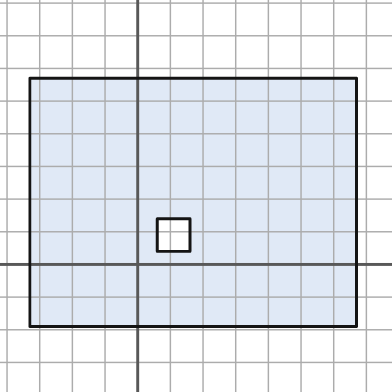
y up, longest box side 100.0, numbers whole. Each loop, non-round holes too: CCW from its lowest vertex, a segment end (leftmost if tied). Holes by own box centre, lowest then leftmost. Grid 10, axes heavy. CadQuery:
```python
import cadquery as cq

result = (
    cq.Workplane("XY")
    .moveTo(-33.0, -19.0)
    .lineTo(67.0, -19.0)
    .lineTo(67.0, 57.0)
    .lineTo(-33.0, 57.0)
    .close()
    .moveTo(6.0, 4.0)
    .lineTo(16.0, 4.0)
    .lineTo(16.0, 14.0)
    .lineTo(6.0, 14.0)
    .close()
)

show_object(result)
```